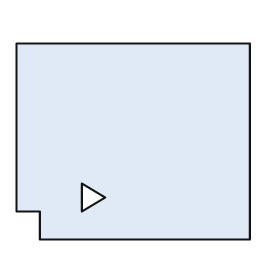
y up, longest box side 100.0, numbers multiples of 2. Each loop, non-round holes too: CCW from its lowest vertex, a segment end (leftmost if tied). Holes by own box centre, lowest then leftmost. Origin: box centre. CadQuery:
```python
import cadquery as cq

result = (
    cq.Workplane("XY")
    .moveTo(-40.0, -42.0)
    .lineTo(50.0, -42.0)
    .lineTo(50.0, 42.0)
    .lineTo(-50.0, 42.0)
    .lineTo(-50.0, -30.0)
    .lineTo(-40.0, -30.0)
    .close()
    .moveTo(-22.0, -30.0)
    .lineTo(-12.0, -24.0)
    .lineTo(-22.0, -18.0)
    .close()
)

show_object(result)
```